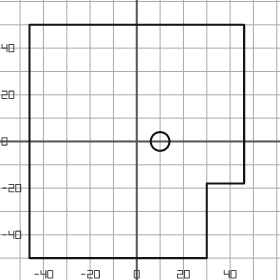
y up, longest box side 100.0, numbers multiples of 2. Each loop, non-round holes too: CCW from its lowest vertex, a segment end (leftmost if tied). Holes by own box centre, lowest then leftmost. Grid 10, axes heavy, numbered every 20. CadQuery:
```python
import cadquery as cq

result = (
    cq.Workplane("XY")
    .moveTo(-46.0, -50.0)
    .lineTo(30.0, -50.0)
    .lineTo(30.0, -18.0)
    .lineTo(46.0, -18.0)
    .lineTo(46.0, 50.0)
    .lineTo(-46.0, 50.0)
    .close()
    .moveTo(10.0, 0.0)
    .circle(4.0)
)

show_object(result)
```